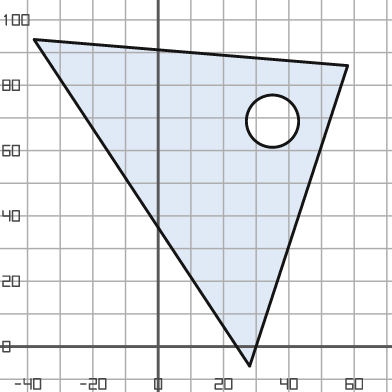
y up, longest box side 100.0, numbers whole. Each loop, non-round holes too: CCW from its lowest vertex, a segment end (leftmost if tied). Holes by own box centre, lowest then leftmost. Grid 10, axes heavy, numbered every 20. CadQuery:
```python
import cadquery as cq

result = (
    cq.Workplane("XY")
    .moveTo(28.0, -6.0)
    .lineTo(58.0, 86.0)
    .lineTo(-38.0, 94.0)
    .close()
    .moveTo(35.0, 69.0)
    .circle(8.0)
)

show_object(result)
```